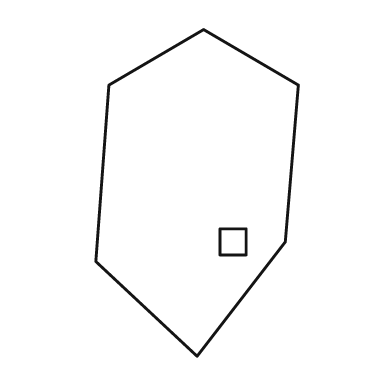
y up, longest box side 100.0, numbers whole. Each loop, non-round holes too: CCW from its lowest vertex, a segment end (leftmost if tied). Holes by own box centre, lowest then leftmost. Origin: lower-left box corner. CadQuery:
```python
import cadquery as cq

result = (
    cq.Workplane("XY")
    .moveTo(31.0, 0.0)
    .lineTo(58.0, 35.0)
    .lineTo(62.0, 83.0)
    .lineTo(33.0, 100.0)
    .lineTo(4.0, 83.0)
    .lineTo(0.0, 29.0)
    .close()
    .moveTo(38.0, 31.0)
    .lineTo(46.0, 31.0)
    .lineTo(46.0, 39.0)
    .lineTo(38.0, 39.0)
    .close()
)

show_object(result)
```